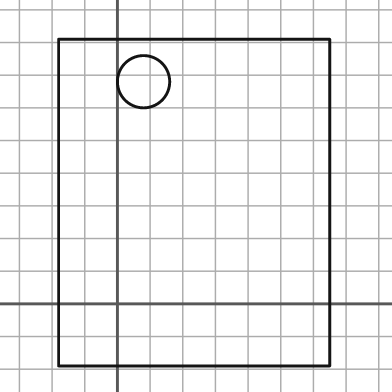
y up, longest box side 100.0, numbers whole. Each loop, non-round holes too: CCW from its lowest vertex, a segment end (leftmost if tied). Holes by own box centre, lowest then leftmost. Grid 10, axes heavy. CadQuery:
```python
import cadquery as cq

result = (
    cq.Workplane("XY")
    .moveTo(-18.0, -19.0)
    .lineTo(65.0, -19.0)
    .lineTo(65.0, 81.0)
    .lineTo(-18.0, 81.0)
    .close()
    .moveTo(8.0, 68.0)
    .circle(8.0)
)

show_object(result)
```